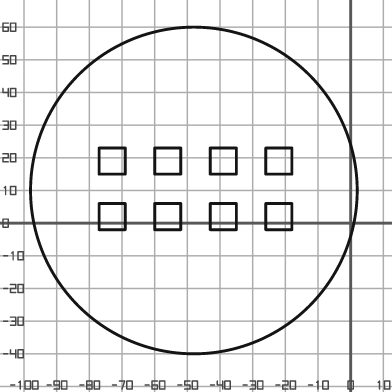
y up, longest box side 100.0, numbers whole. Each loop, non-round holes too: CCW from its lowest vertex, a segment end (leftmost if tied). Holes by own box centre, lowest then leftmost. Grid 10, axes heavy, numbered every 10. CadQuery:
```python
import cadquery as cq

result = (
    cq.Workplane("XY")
    .moveTo(-48.0, 10.0)
    .circle(50.0)
    .moveTo(-77.0, -2.0)
    .lineTo(-69.0, -2.0)
    .lineTo(-69.0, 6.0)
    .lineTo(-77.0, 6.0)
    .close()
    .moveTo(-60.0, -2.0)
    .lineTo(-52.0, -2.0)
    .lineTo(-52.0, 6.0)
    .lineTo(-60.0, 6.0)
    .close()
    .moveTo(-43.0, -2.0)
    .lineTo(-35.0, -2.0)
    .lineTo(-35.0, 6.0)
    .lineTo(-43.0, 6.0)
    .close()
    .moveTo(-26.0, -2.0)
    .lineTo(-18.0, -2.0)
    .lineTo(-18.0, 6.0)
    .lineTo(-26.0, 6.0)
    .close()
    .moveTo(-77.0, 15.0)
    .lineTo(-69.0, 15.0)
    .lineTo(-69.0, 23.0)
    .lineTo(-77.0, 23.0)
    .close()
    .moveTo(-60.0, 15.0)
    .lineTo(-52.0, 15.0)
    .lineTo(-52.0, 23.0)
    .lineTo(-60.0, 23.0)
    .close()
    .moveTo(-43.0, 15.0)
    .lineTo(-35.0, 15.0)
    .lineTo(-35.0, 23.0)
    .lineTo(-43.0, 23.0)
    .close()
    .moveTo(-26.0, 15.0)
    .lineTo(-18.0, 15.0)
    .lineTo(-18.0, 23.0)
    .lineTo(-26.0, 23.0)
    .close()
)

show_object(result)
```